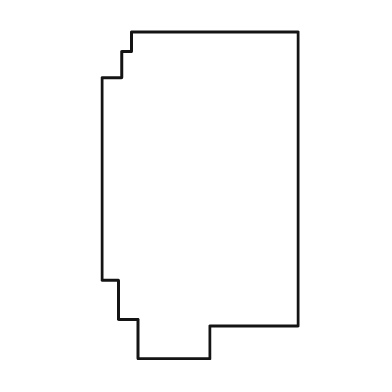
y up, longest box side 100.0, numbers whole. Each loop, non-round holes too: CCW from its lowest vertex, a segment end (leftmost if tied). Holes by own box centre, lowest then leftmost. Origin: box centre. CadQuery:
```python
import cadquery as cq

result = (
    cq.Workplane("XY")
    .moveTo(-19.0, -50.0)
    .lineTo(3.0, -50.0)
    .lineTo(3.0, -40.0)
    .lineTo(30.0, -40.0)
    .lineTo(30.0, 50.0)
    .lineTo(-21.0, 50.0)
    .lineTo(-21.0, 44.0)
    .lineTo(-24.0, 44.0)
    .lineTo(-24.0, 36.0)
    .lineTo(-30.0, 36.0)
    .lineTo(-30.0, -26.0)
    .lineTo(-25.0, -26.0)
    .lineTo(-25.0, -38.0)
    .lineTo(-19.0, -38.0)
    .close()
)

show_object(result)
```